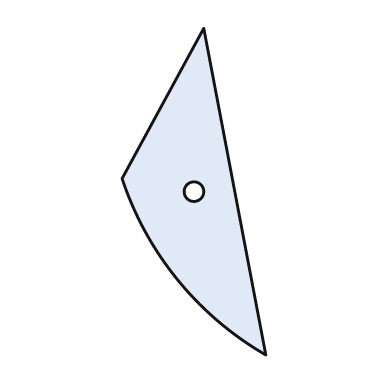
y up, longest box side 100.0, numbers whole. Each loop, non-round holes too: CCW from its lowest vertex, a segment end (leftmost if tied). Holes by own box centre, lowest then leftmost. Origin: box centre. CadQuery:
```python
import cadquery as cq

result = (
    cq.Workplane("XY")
    .moveTo(22.0, -50.0)
    .lineTo(3.0, 50.0)
    .lineTo(-22.0, 4.0)
    .threePointArc((-5.0, -27.0), (22.0, -50.0))
    .close()
    .moveTo(0.0, 0.0)
    .circle(3.0)
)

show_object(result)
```